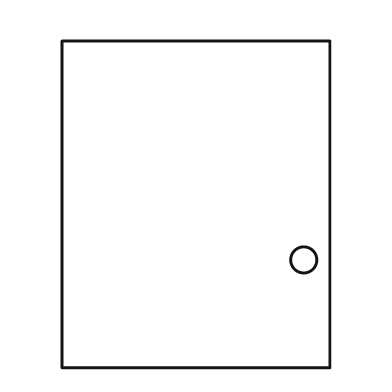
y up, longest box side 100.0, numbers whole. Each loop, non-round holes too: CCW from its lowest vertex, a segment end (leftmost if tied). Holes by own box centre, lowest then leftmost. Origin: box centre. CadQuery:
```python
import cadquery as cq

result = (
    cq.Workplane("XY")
    .moveTo(-41.0, -50.0)
    .lineTo(41.0, -50.0)
    .lineTo(41.0, 50.0)
    .lineTo(-41.0, 50.0)
    .close()
    .moveTo(33.0, -17.0)
    .circle(4.0)
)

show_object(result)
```